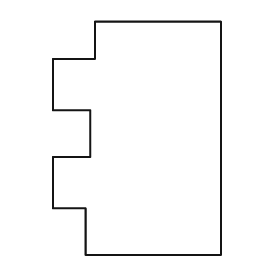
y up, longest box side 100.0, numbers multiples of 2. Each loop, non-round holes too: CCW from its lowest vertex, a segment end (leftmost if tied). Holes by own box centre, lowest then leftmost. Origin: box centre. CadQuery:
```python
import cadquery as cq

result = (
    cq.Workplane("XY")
    .moveTo(-22.0, -50.0)
    .lineTo(36.0, -50.0)
    .lineTo(36.0, 50.0)
    .lineTo(-18.0, 50.0)
    .lineTo(-18.0, 34.0)
    .lineTo(-36.0, 34.0)
    .lineTo(-36.0, 12.0)
    .lineTo(-20.0, 12.0)
    .lineTo(-20.0, -8.0)
    .lineTo(-36.0, -8.0)
    .lineTo(-36.0, -30.0)
    .lineTo(-22.0, -30.0)
    .close()
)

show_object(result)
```